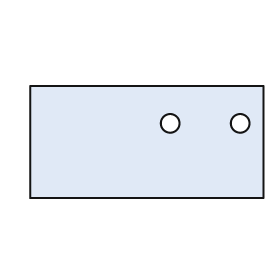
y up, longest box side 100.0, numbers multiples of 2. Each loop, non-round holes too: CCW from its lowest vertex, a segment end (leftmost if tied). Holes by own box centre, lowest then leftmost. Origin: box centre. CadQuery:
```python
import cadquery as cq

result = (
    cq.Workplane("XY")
    .moveTo(-50.0, -24.0)
    .lineTo(50.0, -24.0)
    .lineTo(50.0, 24.0)
    .lineTo(-50.0, 24.0)
    .close()
    .moveTo(10.0, 8.0)
    .circle(4.0)
    .moveTo(40.0, 8.0)
    .circle(4.0)
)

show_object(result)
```